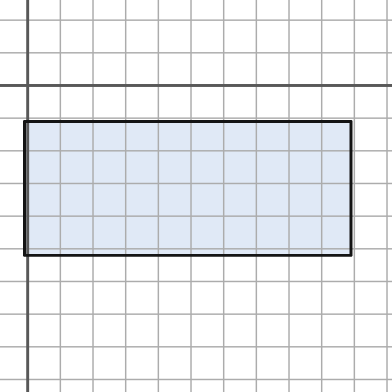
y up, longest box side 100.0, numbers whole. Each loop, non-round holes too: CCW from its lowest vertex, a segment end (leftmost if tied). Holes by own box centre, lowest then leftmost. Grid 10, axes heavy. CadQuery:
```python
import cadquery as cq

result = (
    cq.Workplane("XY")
    .moveTo(-1.0, -52.0)
    .lineTo(99.0, -52.0)
    .lineTo(99.0, -11.0)
    .lineTo(-1.0, -11.0)
    .close()
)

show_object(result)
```